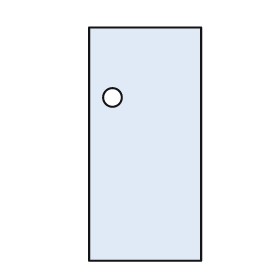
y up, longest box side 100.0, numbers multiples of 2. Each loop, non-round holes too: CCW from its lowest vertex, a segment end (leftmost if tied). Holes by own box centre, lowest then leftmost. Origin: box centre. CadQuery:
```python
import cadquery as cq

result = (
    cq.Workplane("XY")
    .moveTo(-24.0, -50.0)
    .lineTo(24.0, -50.0)
    .lineTo(24.0, 50.0)
    .lineTo(-24.0, 50.0)
    .close()
    .moveTo(-14.0, 20.0)
    .circle(4.0)
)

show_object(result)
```